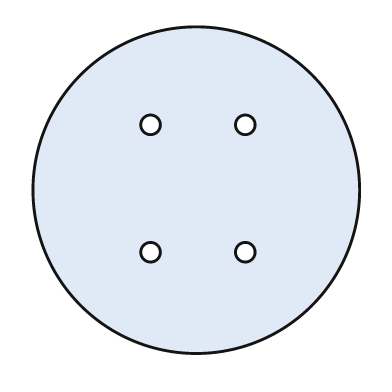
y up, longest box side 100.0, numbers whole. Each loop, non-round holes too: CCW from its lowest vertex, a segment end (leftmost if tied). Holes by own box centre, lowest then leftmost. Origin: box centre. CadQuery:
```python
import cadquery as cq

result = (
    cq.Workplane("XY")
    .moveTo(0.0, 0.0)
    .circle(50.0)
    .moveTo(-14.0, -19.0)
    .circle(3.0)
    .moveTo(15.0, -19.0)
    .circle(3.0)
    .moveTo(-14.0, 20.0)
    .circle(3.0)
    .moveTo(15.0, 20.0)
    .circle(3.0)
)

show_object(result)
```